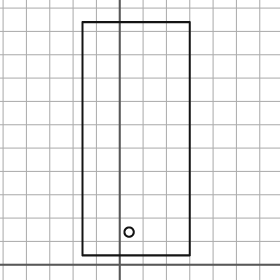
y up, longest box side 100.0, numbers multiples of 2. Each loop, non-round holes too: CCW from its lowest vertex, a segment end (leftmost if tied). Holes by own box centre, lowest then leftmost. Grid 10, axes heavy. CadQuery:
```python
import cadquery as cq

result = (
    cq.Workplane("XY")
    .moveTo(-16.0, 4.0)
    .lineTo(30.0, 4.0)
    .lineTo(30.0, 104.0)
    .lineTo(-16.0, 104.0)
    .close()
    .moveTo(4.0, 14.0)
    .circle(2.0)
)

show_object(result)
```